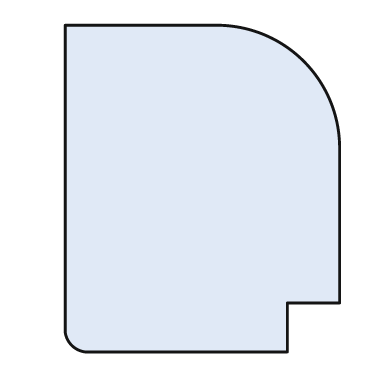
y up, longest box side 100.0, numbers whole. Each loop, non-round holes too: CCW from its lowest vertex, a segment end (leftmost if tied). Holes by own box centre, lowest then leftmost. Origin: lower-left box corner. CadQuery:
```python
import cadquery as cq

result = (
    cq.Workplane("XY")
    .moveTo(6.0, 0.0)
    .lineTo(68.0, 0.0)
    .lineTo(68.0, 15.0)
    .lineTo(84.0, 15.0)
    .lineTo(84.0, 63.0)
    .threePointArc((73.0, 89.0), (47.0, 100.0))
    .lineTo(0.0, 100.0)
    .lineTo(0.0, 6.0)
    .threePointArc((2.0, 2.0), (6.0, 0.0))
    .close()
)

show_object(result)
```